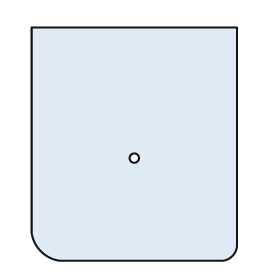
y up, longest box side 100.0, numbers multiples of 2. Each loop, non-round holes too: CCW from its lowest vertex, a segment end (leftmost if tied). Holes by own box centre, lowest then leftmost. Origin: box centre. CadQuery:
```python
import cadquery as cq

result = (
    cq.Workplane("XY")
    .moveTo(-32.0, -50.0)
    .lineTo(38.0, -50.0)
    .threePointArc((42.0, -48.0), (44.0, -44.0))
    .lineTo(44.0, 50.0)
    .lineTo(-44.0, 50.0)
    .lineTo(-44.0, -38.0)
    .threePointArc((-40.0, -46.0), (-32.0, -50.0))
    .close()
    .moveTo(0.0, -6.0)
    .circle(2.0)
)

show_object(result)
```